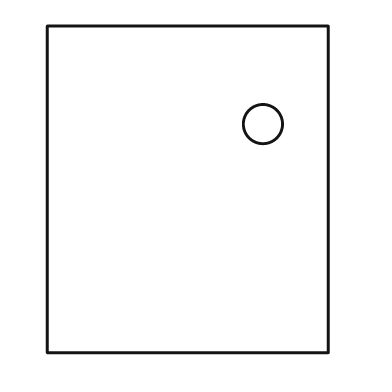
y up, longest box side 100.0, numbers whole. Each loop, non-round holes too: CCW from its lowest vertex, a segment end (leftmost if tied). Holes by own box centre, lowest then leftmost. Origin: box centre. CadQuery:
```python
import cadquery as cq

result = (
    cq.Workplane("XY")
    .moveTo(-43.0, -50.0)
    .lineTo(43.0, -50.0)
    .lineTo(43.0, 50.0)
    .lineTo(-43.0, 50.0)
    .close()
    .moveTo(23.0, 20.0)
    .circle(6.0)
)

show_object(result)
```